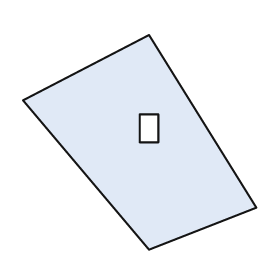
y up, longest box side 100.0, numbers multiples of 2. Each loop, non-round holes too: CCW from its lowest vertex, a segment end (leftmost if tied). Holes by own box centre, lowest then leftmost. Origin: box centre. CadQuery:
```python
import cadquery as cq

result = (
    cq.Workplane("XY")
    .moveTo(4.0, -46.0)
    .lineTo(50.0, -28.0)
    .lineTo(4.0, 46.0)
    .lineTo(-50.0, 18.0)
    .close()
    .moveTo(0.0, 0.0)
    .lineTo(8.0, 0.0)
    .lineTo(8.0, 12.0)
    .lineTo(0.0, 12.0)
    .close()
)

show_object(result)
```